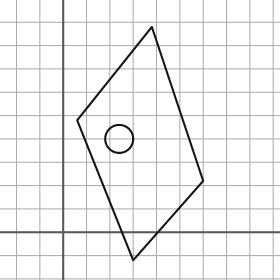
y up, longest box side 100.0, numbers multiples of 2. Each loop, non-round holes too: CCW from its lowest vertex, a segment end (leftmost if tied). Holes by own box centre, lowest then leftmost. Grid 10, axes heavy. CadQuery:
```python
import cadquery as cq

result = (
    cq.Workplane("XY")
    .moveTo(30.0, -12.0)
    .lineTo(60.0, 22.0)
    .lineTo(38.0, 88.0)
    .lineTo(6.0, 48.0)
    .close()
    .moveTo(24.0, 40.0)
    .circle(6.0)
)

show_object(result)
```